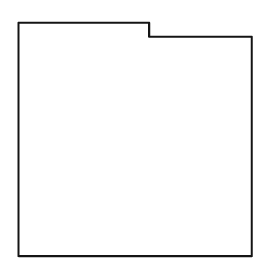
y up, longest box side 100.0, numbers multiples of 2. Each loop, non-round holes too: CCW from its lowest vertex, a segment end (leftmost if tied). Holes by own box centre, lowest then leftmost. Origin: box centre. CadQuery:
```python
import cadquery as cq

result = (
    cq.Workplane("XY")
    .moveTo(-50.0, -50.0)
    .lineTo(50.0, -50.0)
    .lineTo(50.0, 44.0)
    .lineTo(6.0, 44.0)
    .lineTo(6.0, 50.0)
    .lineTo(-50.0, 50.0)
    .close()
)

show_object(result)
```